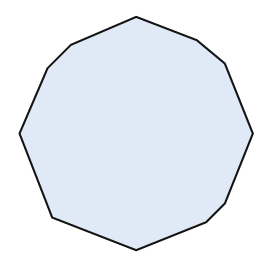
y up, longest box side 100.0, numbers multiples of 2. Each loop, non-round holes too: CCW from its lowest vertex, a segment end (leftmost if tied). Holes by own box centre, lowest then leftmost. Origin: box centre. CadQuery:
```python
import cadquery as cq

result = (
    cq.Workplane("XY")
    .moveTo(0.0, -50.0)
    .lineTo(30.0, -38.0)
    .lineTo(38.0, -30.0)
    .lineTo(50.0, 0.0)
    .lineTo(38.0, 30.0)
    .lineTo(26.0, 40.0)
    .lineTo(0.0, 50.0)
    .lineTo(-28.0, 38.0)
    .lineTo(-38.0, 28.0)
    .lineTo(-50.0, 0.0)
    .lineTo(-36.0, -36.0)
    .close()
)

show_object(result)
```